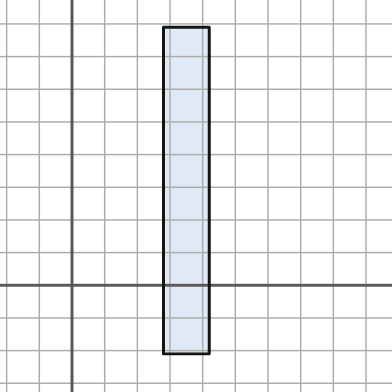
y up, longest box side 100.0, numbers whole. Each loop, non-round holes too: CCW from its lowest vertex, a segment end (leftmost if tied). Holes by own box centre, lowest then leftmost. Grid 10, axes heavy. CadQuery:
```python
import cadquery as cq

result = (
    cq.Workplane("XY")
    .moveTo(28.0, -21.0)
    .lineTo(42.0, -21.0)
    .lineTo(42.0, 79.0)
    .lineTo(28.0, 79.0)
    .close()
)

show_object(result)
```